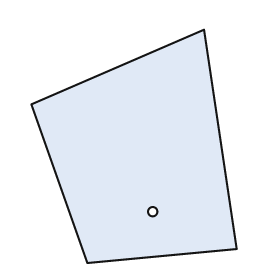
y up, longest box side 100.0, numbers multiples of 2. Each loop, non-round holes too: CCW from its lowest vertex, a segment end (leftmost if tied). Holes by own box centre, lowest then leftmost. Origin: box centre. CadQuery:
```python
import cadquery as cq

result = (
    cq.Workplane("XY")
    .moveTo(-20.0, -50.0)
    .lineTo(44.0, -44.0)
    .lineTo(30.0, 50.0)
    .lineTo(-44.0, 18.0)
    .close()
    .moveTo(8.0, -28.0)
    .circle(2.0)
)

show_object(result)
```